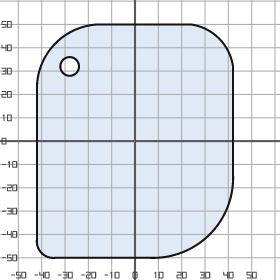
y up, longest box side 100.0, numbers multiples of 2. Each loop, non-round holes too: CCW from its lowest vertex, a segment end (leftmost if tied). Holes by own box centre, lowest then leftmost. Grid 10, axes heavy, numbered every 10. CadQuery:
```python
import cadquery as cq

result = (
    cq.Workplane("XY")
    .moveTo(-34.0, -50.0)
    .lineTo(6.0, -50.0)
    .threePointArc((32.0, -40.0), (42.0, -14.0))
    .lineTo(42.0, 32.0)
    .threePointArc((36.0, 44.0), (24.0, 50.0))
    .lineTo(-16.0, 50.0)
    .threePointArc((-34.0, 42.0), (-42.0, 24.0))
    .lineTo(-42.0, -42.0)
    .threePointArc((-40.0, -48.0), (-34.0, -50.0))
    .close()
    .moveTo(-28.0, 32.0)
    .circle(4.0)
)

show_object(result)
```